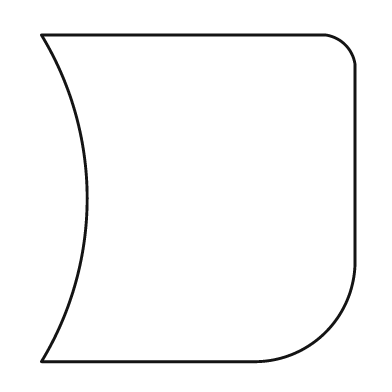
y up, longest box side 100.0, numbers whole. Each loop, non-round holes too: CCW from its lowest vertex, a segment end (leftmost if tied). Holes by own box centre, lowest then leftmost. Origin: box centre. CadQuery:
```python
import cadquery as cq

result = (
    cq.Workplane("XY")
    .moveTo(-48.0, -50.0)
    .lineTo(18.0, -50.0)
    .threePointArc((39.0, -41.0), (48.0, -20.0))
    .lineTo(48.0, 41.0)
    .threePointArc((45.0, 47.0), (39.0, 50.0))
    .lineTo(-48.0, 50.0)
    .threePointArc((-34.0, 0.0), (-48.0, -50.0))
    .close()
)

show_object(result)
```